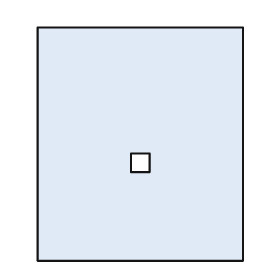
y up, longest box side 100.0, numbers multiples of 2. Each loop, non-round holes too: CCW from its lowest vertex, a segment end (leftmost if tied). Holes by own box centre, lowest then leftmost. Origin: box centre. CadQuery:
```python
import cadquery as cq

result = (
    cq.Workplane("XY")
    .moveTo(-44.0, -50.0)
    .lineTo(44.0, -50.0)
    .lineTo(44.0, 50.0)
    .lineTo(-44.0, 50.0)
    .close()
    .moveTo(-4.0, -12.0)
    .lineTo(4.0, -12.0)
    .lineTo(4.0, -4.0)
    .lineTo(-4.0, -4.0)
    .close()
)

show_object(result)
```